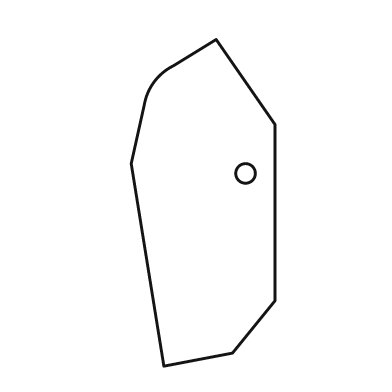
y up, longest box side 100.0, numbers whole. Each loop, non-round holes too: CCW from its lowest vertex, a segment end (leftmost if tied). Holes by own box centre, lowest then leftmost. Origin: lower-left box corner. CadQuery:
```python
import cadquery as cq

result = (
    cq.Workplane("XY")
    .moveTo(10.0, 0.0)
    .lineTo(31.0, 4.0)
    .lineTo(44.0, 20.0)
    .lineTo(44.0, 74.0)
    .lineTo(26.0, 100.0)
    .lineTo(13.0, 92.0)
    .threePointArc((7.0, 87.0), (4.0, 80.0))
    .lineTo(0.0, 62.0)
    .close()
    .moveTo(35.0, 59.0)
    .circle(3.0)
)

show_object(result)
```